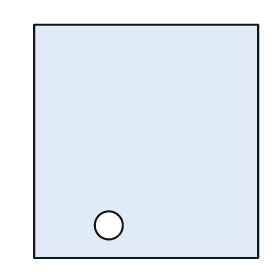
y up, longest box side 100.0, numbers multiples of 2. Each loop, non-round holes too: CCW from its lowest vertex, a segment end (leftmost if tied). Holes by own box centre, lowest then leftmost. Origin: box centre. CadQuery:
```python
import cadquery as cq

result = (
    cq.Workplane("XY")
    .moveTo(-48.0, -50.0)
    .lineTo(48.0, -50.0)
    .lineTo(48.0, 50.0)
    .lineTo(-48.0, 50.0)
    .close()
    .moveTo(-16.0, -36.0)
    .circle(6.0)
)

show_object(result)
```